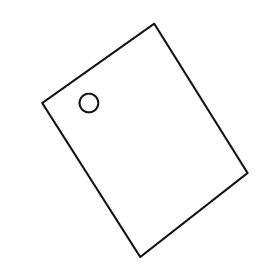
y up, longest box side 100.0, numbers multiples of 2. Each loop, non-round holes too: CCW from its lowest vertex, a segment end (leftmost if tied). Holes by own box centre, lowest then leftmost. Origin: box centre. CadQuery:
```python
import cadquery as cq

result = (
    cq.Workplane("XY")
    .moveTo(-2.0, -50.0)
    .lineTo(44.0, -14.0)
    .lineTo(4.0, 50.0)
    .lineTo(-44.0, 16.0)
    .close()
    .moveTo(-24.0, 16.0)
    .circle(4.0)
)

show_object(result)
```